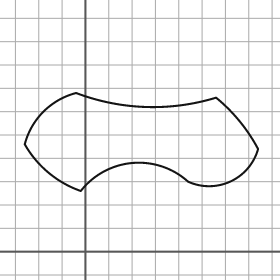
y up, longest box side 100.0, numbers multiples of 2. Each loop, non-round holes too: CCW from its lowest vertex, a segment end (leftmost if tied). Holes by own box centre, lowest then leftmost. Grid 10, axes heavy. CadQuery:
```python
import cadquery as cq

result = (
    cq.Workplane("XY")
    .moveTo(-2.0, 26.0)
    .threePointArc((20.0, 38.0), (44.0, 30.0))
    .threePointArc((62.0, 30.0), (74.0, 44.0))
    .threePointArc((66.0, 56.0), (56.0, 66.0))
    .threePointArc((26.0, 62.0), (-4.0, 68.0))
    .threePointArc((-18.0, 60.0), (-26.0, 46.0))
    .threePointArc((-16.0, 34.0), (-2.0, 26.0))
    .close()
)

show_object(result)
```